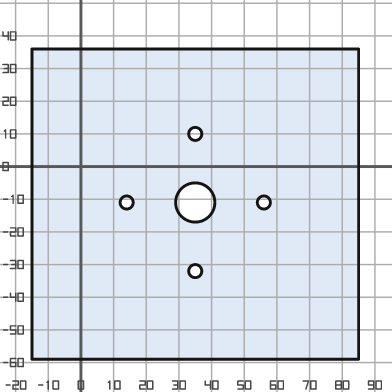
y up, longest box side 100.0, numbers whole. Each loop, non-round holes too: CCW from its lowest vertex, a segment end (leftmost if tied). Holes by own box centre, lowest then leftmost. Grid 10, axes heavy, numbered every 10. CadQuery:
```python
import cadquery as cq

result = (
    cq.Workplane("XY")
    .moveTo(-15.0, -59.0)
    .lineTo(85.0, -59.0)
    .lineTo(85.0, 36.0)
    .lineTo(-15.0, 36.0)
    .close()
    .moveTo(35.0, -32.0)
    .circle(2.0)
    .moveTo(14.0, -11.0)
    .circle(2.0)
    .moveTo(35.0, -11.0)
    .circle(6.0)
    .moveTo(56.0, -11.0)
    .circle(2.0)
    .moveTo(35.0, 10.0)
    .circle(2.0)
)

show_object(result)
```